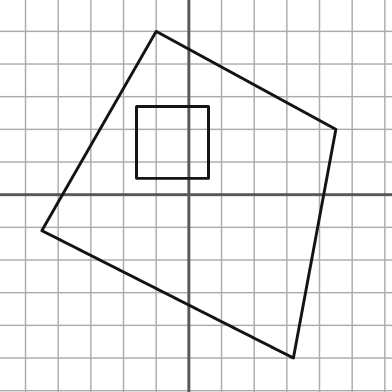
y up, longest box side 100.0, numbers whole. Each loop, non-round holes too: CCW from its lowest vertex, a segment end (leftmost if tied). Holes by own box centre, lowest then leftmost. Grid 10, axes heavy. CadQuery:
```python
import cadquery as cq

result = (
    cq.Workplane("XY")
    .moveTo(32.0, -50.0)
    .lineTo(45.0, 20.0)
    .lineTo(-10.0, 50.0)
    .lineTo(-45.0, -11.0)
    .close()
    .moveTo(-16.0, 5.0)
    .lineTo(6.0, 5.0)
    .lineTo(6.0, 27.0)
    .lineTo(-16.0, 27.0)
    .close()
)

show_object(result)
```